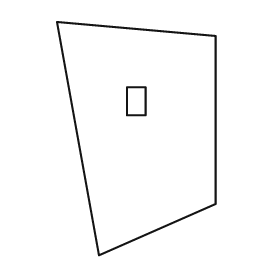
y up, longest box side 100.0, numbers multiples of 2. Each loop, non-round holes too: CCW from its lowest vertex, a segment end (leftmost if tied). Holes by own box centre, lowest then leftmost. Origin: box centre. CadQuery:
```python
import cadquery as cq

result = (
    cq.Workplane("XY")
    .moveTo(-16.0, -50.0)
    .lineTo(34.0, -28.0)
    .lineTo(34.0, 44.0)
    .lineTo(-34.0, 50.0)
    .close()
    .moveTo(-4.0, 10.0)
    .lineTo(4.0, 10.0)
    .lineTo(4.0, 22.0)
    .lineTo(-4.0, 22.0)
    .close()
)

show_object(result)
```